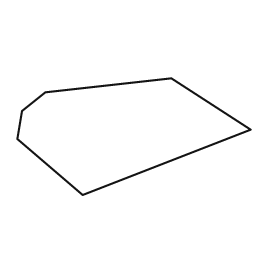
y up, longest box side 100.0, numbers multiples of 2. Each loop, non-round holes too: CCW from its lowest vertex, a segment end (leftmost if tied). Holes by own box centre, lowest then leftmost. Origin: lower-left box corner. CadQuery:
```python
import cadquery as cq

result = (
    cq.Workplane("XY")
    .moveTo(28.0, 0.0)
    .lineTo(100.0, 28.0)
    .lineTo(66.0, 50.0)
    .lineTo(12.0, 44.0)
    .lineTo(2.0, 36.0)
    .lineTo(0.0, 24.0)
    .close()
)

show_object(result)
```